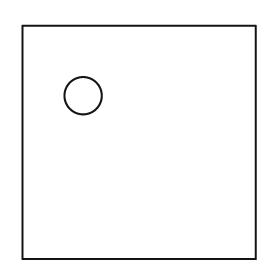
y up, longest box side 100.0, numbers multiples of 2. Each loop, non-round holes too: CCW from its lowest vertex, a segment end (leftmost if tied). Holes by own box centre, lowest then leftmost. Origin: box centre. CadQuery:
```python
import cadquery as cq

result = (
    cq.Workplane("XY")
    .moveTo(-50.0, -50.0)
    .lineTo(50.0, -50.0)
    .lineTo(50.0, 50.0)
    .lineTo(-50.0, 50.0)
    .close()
    .moveTo(-24.0, 20.0)
    .circle(8.0)
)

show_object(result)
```